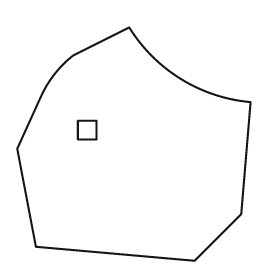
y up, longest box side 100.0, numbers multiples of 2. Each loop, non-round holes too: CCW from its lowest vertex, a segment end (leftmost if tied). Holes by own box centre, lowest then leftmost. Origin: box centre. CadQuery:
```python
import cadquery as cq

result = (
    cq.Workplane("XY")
    .moveTo(26.0, -50.0)
    .lineTo(46.0, -30.0)
    .lineTo(50.0, 18.0)
    .threePointArc((20.0, 28.0), (-2.0, 50.0))
    .lineTo(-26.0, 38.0)
    .threePointArc((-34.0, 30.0), (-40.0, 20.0))
    .lineTo(-50.0, -2.0)
    .lineTo(-42.0, -44.0)
    .close()
    .moveTo(-24.0, 2.0)
    .lineTo(-16.0, 2.0)
    .lineTo(-16.0, 10.0)
    .lineTo(-24.0, 10.0)
    .close()
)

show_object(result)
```